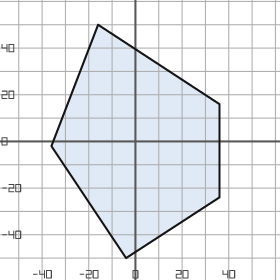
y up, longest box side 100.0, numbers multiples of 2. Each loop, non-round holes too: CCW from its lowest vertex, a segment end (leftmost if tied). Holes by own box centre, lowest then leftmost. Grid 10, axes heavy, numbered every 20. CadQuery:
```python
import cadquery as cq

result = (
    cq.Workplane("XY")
    .moveTo(-4.0, -50.0)
    .lineTo(36.0, -24.0)
    .lineTo(36.0, 16.0)
    .lineTo(-16.0, 50.0)
    .lineTo(-36.0, -2.0)
    .close()
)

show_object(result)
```